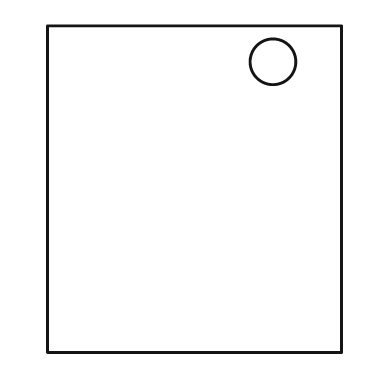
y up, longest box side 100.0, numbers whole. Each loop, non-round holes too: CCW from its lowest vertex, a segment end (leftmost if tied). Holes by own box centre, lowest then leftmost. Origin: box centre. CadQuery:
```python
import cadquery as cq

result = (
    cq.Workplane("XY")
    .moveTo(-45.0, -50.0)
    .lineTo(45.0, -50.0)
    .lineTo(45.0, 50.0)
    .lineTo(-45.0, 50.0)
    .close()
    .moveTo(24.0, 39.0)
    .circle(7.0)
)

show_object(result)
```